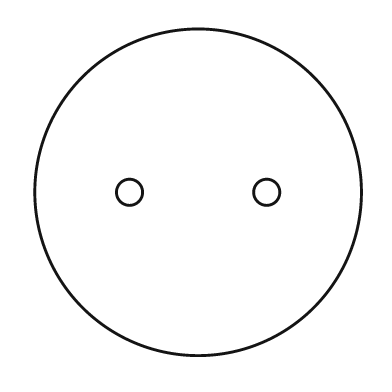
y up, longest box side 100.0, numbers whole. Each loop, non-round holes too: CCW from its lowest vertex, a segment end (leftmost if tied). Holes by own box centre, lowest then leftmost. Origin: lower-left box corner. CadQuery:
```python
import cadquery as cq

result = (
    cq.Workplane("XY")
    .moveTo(50.0, 50.0)
    .circle(50.0)
    .moveTo(29.0, 50.0)
    .circle(4.0)
    .moveTo(71.0, 50.0)
    .circle(4.0)
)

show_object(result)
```